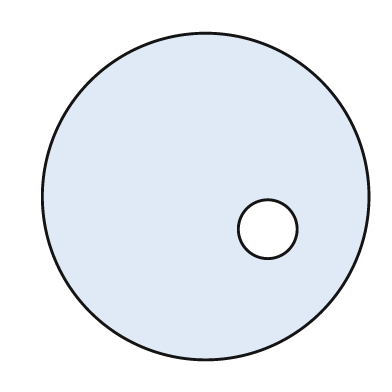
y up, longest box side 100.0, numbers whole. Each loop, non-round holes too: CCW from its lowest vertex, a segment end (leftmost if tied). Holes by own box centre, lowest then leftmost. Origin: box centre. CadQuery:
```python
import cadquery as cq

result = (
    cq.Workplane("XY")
    .moveTo(0.0, 0.0)
    .circle(50.0)
    .moveTo(19.0, -10.0)
    .circle(9.0)
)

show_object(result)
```